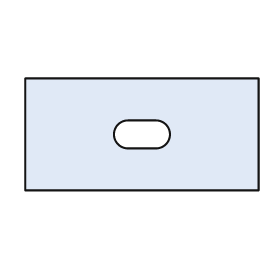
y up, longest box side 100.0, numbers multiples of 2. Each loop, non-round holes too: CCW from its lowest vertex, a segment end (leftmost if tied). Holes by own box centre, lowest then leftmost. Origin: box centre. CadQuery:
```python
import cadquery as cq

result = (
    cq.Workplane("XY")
    .moveTo(-50.0, -24.0)
    .lineTo(50.0, -24.0)
    .lineTo(50.0, 24.0)
    .lineTo(-50.0, 24.0)
    .close()
    .moveTo(-6.0, -6.0)
    .lineTo(6.0, -6.0)
    .threePointArc((12.0, 0.0), (6.0, 6.0))
    .lineTo(-6.0, 6.0)
    .threePointArc((-12.0, 0.0), (-6.0, -6.0))
    .close()
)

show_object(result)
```